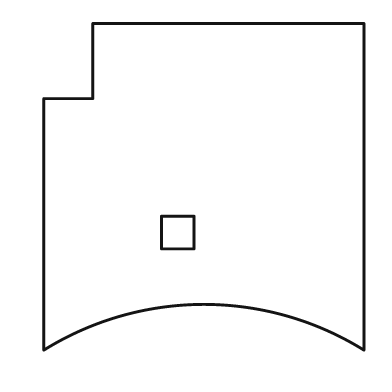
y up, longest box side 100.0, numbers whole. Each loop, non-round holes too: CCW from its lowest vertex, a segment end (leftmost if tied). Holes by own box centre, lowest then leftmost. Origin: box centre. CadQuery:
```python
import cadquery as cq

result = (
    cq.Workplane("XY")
    .moveTo(-49.0, -50.0)
    .threePointArc((0.0, -36.0), (49.0, -50.0))
    .lineTo(49.0, 50.0)
    .lineTo(-34.0, 50.0)
    .lineTo(-34.0, 27.0)
    .lineTo(-49.0, 27.0)
    .close()
    .moveTo(-13.0, -19.0)
    .lineTo(-3.0, -19.0)
    .lineTo(-3.0, -9.0)
    .lineTo(-13.0, -9.0)
    .close()
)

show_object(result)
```